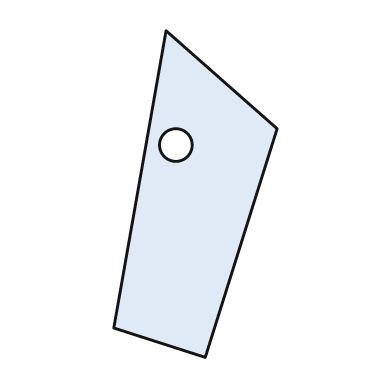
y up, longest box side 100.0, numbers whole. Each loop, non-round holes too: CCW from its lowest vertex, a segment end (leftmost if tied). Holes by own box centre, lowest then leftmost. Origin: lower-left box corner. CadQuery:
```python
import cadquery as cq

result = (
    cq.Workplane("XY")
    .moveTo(28.0, 0.0)
    .lineTo(50.0, 70.0)
    .lineTo(16.0, 100.0)
    .lineTo(0.0, 9.0)
    .close()
    .moveTo(19.0, 65.0)
    .circle(5.0)
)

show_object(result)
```